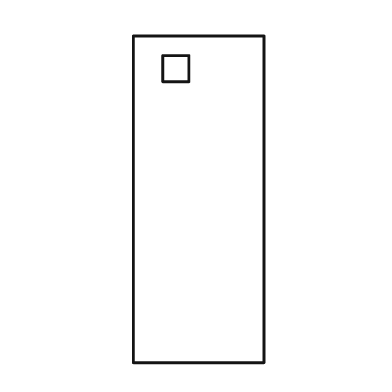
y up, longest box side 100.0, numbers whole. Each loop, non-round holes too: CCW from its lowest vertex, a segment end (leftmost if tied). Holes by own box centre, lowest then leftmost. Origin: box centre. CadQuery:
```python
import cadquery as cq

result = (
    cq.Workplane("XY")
    .moveTo(-20.0, -50.0)
    .lineTo(20.0, -50.0)
    .lineTo(20.0, 50.0)
    .lineTo(-20.0, 50.0)
    .close()
    .moveTo(-11.0, 36.0)
    .lineTo(-3.0, 36.0)
    .lineTo(-3.0, 44.0)
    .lineTo(-11.0, 44.0)
    .close()
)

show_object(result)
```